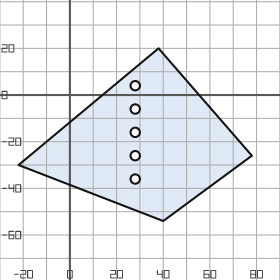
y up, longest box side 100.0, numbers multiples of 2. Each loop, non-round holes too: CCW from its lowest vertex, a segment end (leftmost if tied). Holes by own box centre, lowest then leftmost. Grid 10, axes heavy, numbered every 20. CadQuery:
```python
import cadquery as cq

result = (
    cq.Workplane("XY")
    .moveTo(40.0, -54.0)
    .lineTo(78.0, -26.0)
    .lineTo(38.0, 20.0)
    .lineTo(-22.0, -30.0)
    .close()
    .moveTo(28.0, -36.0)
    .circle(2.0)
    .moveTo(28.0, -26.0)
    .circle(2.0)
    .moveTo(28.0, -16.0)
    .circle(2.0)
    .moveTo(28.0, -6.0)
    .circle(2.0)
    .moveTo(28.0, 4.0)
    .circle(2.0)
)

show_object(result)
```